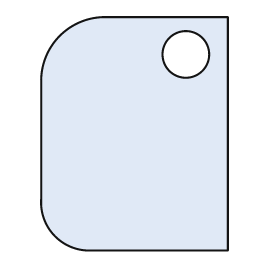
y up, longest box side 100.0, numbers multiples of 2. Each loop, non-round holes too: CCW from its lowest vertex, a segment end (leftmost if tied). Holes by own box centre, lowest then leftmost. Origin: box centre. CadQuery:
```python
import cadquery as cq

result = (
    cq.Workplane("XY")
    .moveTo(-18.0, -50.0)
    .lineTo(40.0, -50.0)
    .lineTo(40.0, 50.0)
    .lineTo(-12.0, 50.0)
    .threePointArc((-32.0, 42.0), (-40.0, 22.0))
    .lineTo(-40.0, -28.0)
    .threePointArc((-34.0, -44.0), (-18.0, -50.0))
    .close()
    .moveTo(22.0, 34.0)
    .circle(10.0)
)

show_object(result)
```